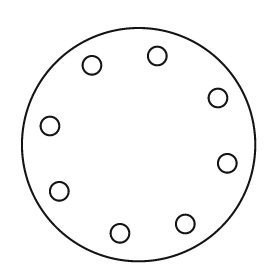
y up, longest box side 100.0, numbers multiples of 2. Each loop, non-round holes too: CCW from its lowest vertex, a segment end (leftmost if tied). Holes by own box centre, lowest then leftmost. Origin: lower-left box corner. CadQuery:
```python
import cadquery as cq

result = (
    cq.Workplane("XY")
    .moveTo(50.0, 50.0)
    .circle(50.0)
    .moveTo(42.0, 12.0)
    .circle(4.0)
    .moveTo(70.0, 16.0)
    .circle(4.0)
    .moveTo(16.0, 30.0)
    .circle(4.0)
    .moveTo(88.0, 42.0)
    .circle(4.0)
    .moveTo(12.0, 58.0)
    .circle(4.0)
    .moveTo(84.0, 70.0)
    .circle(4.0)
    .moveTo(30.0, 84.0)
    .circle(4.0)
    .moveTo(58.0, 88.0)
    .circle(4.0)
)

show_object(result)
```